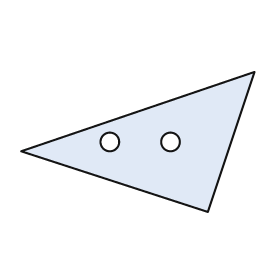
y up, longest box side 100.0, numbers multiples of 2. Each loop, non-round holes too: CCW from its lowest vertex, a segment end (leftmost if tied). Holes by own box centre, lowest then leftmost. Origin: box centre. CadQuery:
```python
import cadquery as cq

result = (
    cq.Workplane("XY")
    .moveTo(30.0, -30.0)
    .lineTo(50.0, 30.0)
    .lineTo(-50.0, -4.0)
    .close()
    .moveTo(-12.0, 0.0)
    .circle(4.0)
    .moveTo(14.0, 0.0)
    .circle(4.0)
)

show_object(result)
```